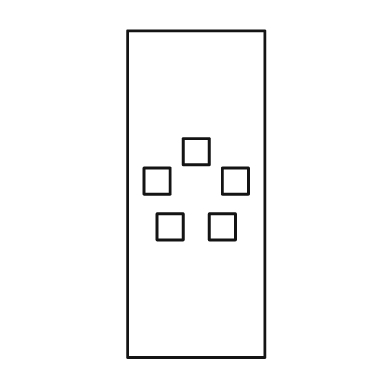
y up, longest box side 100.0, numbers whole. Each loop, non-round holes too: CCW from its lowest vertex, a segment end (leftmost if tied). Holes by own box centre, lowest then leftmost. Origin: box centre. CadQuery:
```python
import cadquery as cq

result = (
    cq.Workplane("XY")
    .moveTo(-21.0, -50.0)
    .lineTo(21.0, -50.0)
    .lineTo(21.0, 50.0)
    .lineTo(-21.0, 50.0)
    .close()
    .moveTo(-12.0, -14.0)
    .lineTo(-4.0, -14.0)
    .lineTo(-4.0, -6.0)
    .lineTo(-12.0, -6.0)
    .close()
    .moveTo(4.0, -14.0)
    .lineTo(12.0, -14.0)
    .lineTo(12.0, -6.0)
    .lineTo(4.0, -6.0)
    .close()
    .moveTo(-16.0, 0.0)
    .lineTo(-8.0, 0.0)
    .lineTo(-8.0, 8.0)
    .lineTo(-16.0, 8.0)
    .close()
    .moveTo(8.0, 0.0)
    .lineTo(16.0, 0.0)
    .lineTo(16.0, 8.0)
    .lineTo(8.0, 8.0)
    .close()
    .moveTo(-4.0, 9.0)
    .lineTo(4.0, 9.0)
    .lineTo(4.0, 17.0)
    .lineTo(-4.0, 17.0)
    .close()
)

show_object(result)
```